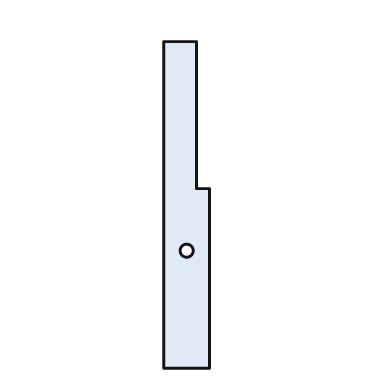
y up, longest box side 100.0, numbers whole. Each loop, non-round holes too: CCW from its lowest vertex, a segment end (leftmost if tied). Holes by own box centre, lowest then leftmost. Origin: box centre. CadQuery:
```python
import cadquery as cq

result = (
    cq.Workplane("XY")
    .moveTo(-7.0, -50.0)
    .lineTo(7.0, -50.0)
    .lineTo(7.0, 5.0)
    .lineTo(3.0, 5.0)
    .lineTo(3.0, 50.0)
    .lineTo(-7.0, 50.0)
    .close()
    .moveTo(0.0, -14.0)
    .circle(2.0)
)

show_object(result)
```